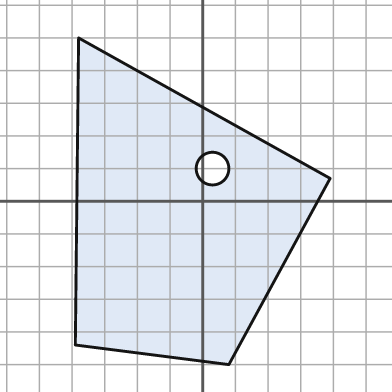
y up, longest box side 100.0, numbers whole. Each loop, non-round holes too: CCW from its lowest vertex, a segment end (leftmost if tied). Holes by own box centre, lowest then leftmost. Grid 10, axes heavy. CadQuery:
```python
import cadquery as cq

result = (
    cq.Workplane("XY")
    .moveTo(8.0, -50.0)
    .lineTo(39.0, 7.0)
    .lineTo(-38.0, 50.0)
    .lineTo(-39.0, -44.0)
    .close()
    .moveTo(3.0, 10.0)
    .circle(5.0)
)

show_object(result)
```